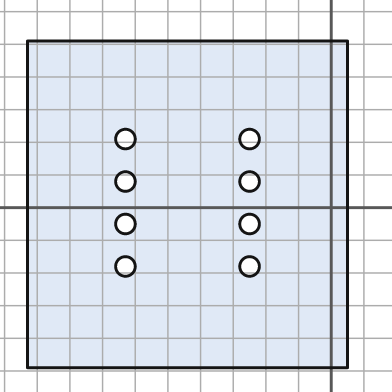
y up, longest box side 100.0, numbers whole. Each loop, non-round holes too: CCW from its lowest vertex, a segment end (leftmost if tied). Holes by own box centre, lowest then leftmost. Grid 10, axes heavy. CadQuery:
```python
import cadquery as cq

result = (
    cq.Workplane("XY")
    .moveTo(-93.0, -49.0)
    .lineTo(5.0, -49.0)
    .lineTo(5.0, 51.0)
    .lineTo(-93.0, 51.0)
    .close()
    .moveTo(-63.0, -18.0)
    .circle(3.0)
    .moveTo(-25.0, -18.0)
    .circle(3.0)
    .moveTo(-63.0, -5.0)
    .circle(3.0)
    .moveTo(-25.0, -5.0)
    .circle(3.0)
    .moveTo(-63.0, 8.0)
    .circle(3.0)
    .moveTo(-25.0, 8.0)
    .circle(3.0)
    .moveTo(-63.0, 21.0)
    .circle(3.0)
    .moveTo(-25.0, 21.0)
    .circle(3.0)
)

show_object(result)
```